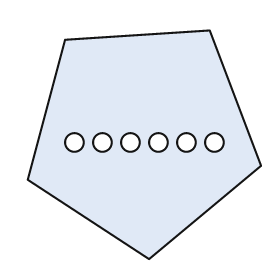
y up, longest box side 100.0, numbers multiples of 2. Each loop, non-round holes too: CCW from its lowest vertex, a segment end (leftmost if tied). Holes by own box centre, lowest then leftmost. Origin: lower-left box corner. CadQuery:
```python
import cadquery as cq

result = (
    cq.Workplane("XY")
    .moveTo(52.0, 0.0)
    .lineTo(100.0, 40.0)
    .lineTo(78.0, 98.0)
    .lineTo(16.0, 94.0)
    .lineTo(0.0, 34.0)
    .close()
    .moveTo(20.0, 50.0)
    .circle(4.0)
    .moveTo(32.0, 50.0)
    .circle(4.0)
    .moveTo(44.0, 50.0)
    .circle(4.0)
    .moveTo(56.0, 50.0)
    .circle(4.0)
    .moveTo(68.0, 50.0)
    .circle(4.0)
    .moveTo(80.0, 50.0)
    .circle(4.0)
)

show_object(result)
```